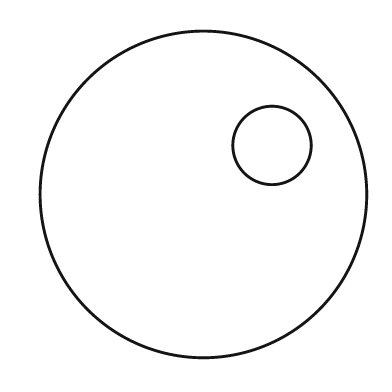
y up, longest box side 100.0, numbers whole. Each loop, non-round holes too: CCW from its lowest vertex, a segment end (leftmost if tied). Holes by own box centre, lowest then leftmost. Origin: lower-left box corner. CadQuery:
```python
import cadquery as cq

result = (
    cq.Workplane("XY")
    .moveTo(50.0, 50.0)
    .circle(50.0)
    .moveTo(71.0, 65.0)
    .circle(12.0)
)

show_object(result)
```